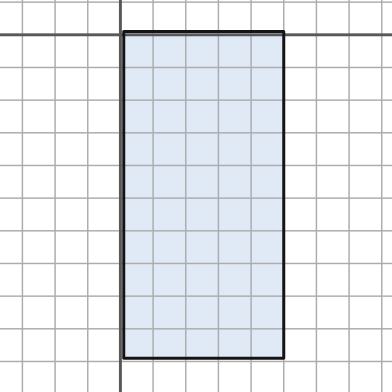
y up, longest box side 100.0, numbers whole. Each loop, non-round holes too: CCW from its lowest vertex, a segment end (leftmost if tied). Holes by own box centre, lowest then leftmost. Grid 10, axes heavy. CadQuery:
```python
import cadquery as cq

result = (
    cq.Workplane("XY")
    .moveTo(1.0, -99.0)
    .lineTo(50.0, -99.0)
    .lineTo(50.0, 1.0)
    .lineTo(1.0, 1.0)
    .close()
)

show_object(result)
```